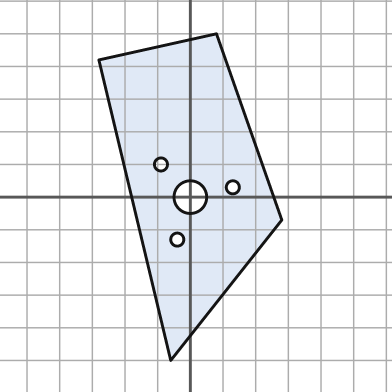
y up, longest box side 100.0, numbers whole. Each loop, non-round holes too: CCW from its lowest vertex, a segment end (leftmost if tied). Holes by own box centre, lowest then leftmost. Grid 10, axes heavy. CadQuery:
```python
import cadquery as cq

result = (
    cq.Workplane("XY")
    .moveTo(-6.0, -50.0)
    .lineTo(28.0, -7.0)
    .lineTo(8.0, 50.0)
    .lineTo(-28.0, 42.0)
    .close()
    .moveTo(-4.0, -13.0)
    .circle(2.0)
    .moveTo(0.0, 0.0)
    .circle(5.0)
    .moveTo(13.0, 3.0)
    .circle(2.0)
    .moveTo(-9.0, 10.0)
    .circle(2.0)
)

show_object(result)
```